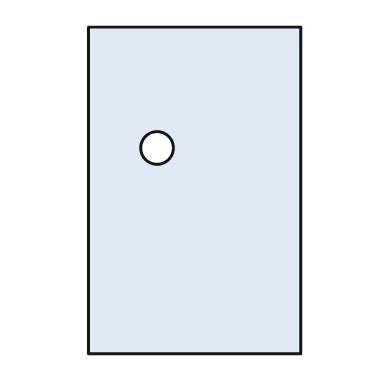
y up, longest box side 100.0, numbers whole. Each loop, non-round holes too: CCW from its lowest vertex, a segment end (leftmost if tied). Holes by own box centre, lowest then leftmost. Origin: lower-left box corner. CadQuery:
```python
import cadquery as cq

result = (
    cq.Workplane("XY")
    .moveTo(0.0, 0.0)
    .lineTo(65.0, 0.0)
    .lineTo(65.0, 100.0)
    .lineTo(0.0, 100.0)
    .close()
    .moveTo(21.0, 63.0)
    .circle(5.0)
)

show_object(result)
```